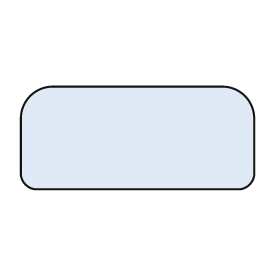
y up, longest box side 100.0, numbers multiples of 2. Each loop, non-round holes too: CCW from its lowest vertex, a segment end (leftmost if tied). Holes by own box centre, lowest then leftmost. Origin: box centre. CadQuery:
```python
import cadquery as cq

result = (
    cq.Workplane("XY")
    .moveTo(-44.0, -22.0)
    .lineTo(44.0, -22.0)
    .threePointArc((48.0, -20.0), (50.0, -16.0))
    .lineTo(50.0, 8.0)
    .threePointArc((46.0, 18.0), (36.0, 22.0))
    .lineTo(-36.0, 22.0)
    .threePointArc((-46.0, 18.0), (-50.0, 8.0))
    .lineTo(-50.0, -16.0)
    .threePointArc((-48.0, -20.0), (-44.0, -22.0))
    .close()
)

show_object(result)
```